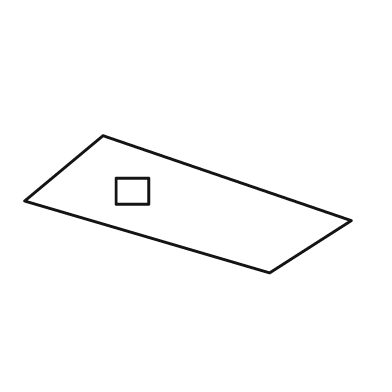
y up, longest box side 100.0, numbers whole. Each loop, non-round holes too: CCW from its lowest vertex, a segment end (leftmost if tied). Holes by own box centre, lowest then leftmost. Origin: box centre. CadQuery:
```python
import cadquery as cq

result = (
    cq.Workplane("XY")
    .moveTo(25.0, -21.0)
    .lineTo(50.0, -5.0)
    .lineTo(-26.0, 21.0)
    .lineTo(-50.0, 1.0)
    .close()
    .moveTo(-22.0, 0.0)
    .lineTo(-12.0, 0.0)
    .lineTo(-12.0, 8.0)
    .lineTo(-22.0, 8.0)
    .close()
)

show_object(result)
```